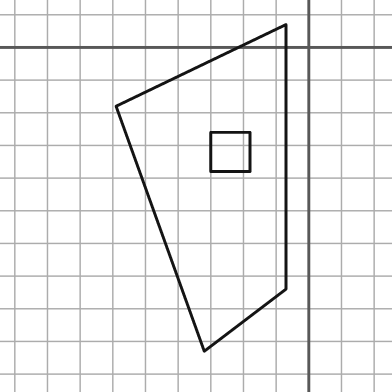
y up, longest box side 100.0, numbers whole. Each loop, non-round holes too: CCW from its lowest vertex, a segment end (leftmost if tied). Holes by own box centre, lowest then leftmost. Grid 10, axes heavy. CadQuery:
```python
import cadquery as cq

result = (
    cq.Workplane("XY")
    .moveTo(-32.0, -93.0)
    .lineTo(-7.0, -74.0)
    .lineTo(-7.0, 7.0)
    .lineTo(-59.0, -18.0)
    .close()
    .moveTo(-30.0, -38.0)
    .lineTo(-18.0, -38.0)
    .lineTo(-18.0, -26.0)
    .lineTo(-30.0, -26.0)
    .close()
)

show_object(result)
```